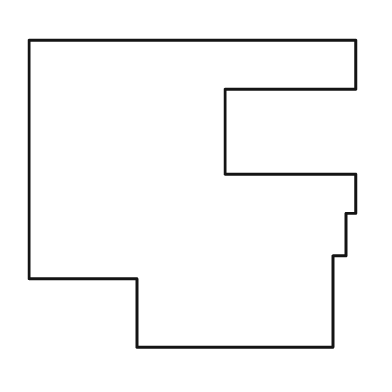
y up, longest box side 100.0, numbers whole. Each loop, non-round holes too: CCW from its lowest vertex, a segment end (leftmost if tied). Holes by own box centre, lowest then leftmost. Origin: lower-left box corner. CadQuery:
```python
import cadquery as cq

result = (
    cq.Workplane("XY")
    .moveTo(33.0, 0.0)
    .lineTo(93.0, 0.0)
    .lineTo(93.0, 28.0)
    .lineTo(97.0, 28.0)
    .lineTo(97.0, 41.0)
    .lineTo(100.0, 41.0)
    .lineTo(100.0, 53.0)
    .lineTo(60.0, 53.0)
    .lineTo(60.0, 79.0)
    .lineTo(100.0, 79.0)
    .lineTo(100.0, 94.0)
    .lineTo(0.0, 94.0)
    .lineTo(0.0, 21.0)
    .lineTo(33.0, 21.0)
    .close()
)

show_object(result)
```